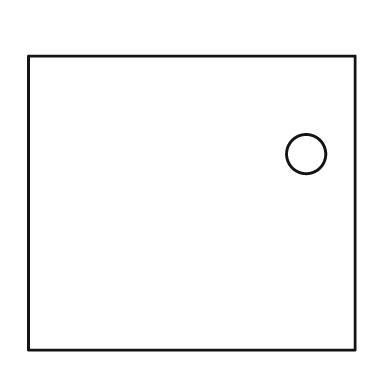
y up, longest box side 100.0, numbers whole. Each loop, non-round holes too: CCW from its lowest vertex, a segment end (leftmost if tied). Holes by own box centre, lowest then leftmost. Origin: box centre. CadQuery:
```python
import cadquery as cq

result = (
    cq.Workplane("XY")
    .moveTo(-50.0, -45.0)
    .lineTo(50.0, -45.0)
    .lineTo(50.0, 45.0)
    .lineTo(-50.0, 45.0)
    .close()
    .moveTo(35.0, 15.0)
    .circle(6.0)
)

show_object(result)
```